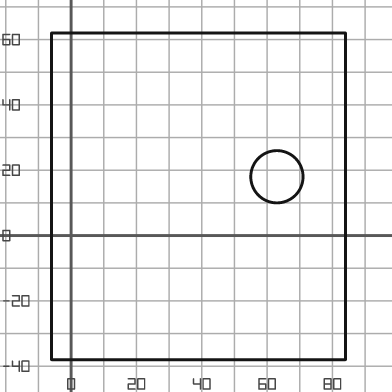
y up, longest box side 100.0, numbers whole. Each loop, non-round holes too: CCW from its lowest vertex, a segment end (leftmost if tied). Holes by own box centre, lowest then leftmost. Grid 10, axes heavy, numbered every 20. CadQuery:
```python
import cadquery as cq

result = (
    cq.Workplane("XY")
    .moveTo(-6.0, -38.0)
    .lineTo(84.0, -38.0)
    .lineTo(84.0, 62.0)
    .lineTo(-6.0, 62.0)
    .close()
    .moveTo(63.0, 18.0)
    .circle(8.0)
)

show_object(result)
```